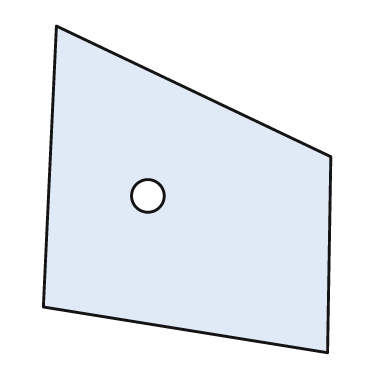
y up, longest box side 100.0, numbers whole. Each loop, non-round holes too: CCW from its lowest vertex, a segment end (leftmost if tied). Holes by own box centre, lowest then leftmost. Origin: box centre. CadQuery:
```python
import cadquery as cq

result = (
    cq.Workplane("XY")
    .moveTo(43.0, -50.0)
    .lineTo(44.0, 10.0)
    .lineTo(-40.0, 50.0)
    .lineTo(-44.0, -36.0)
    .close()
    .moveTo(-12.0, -2.0)
    .circle(5.0)
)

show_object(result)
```